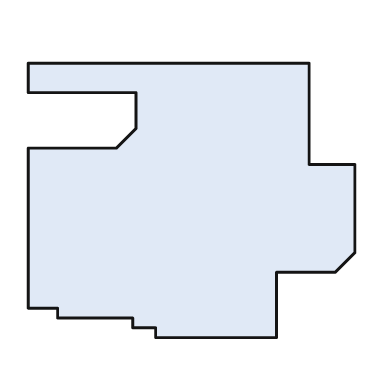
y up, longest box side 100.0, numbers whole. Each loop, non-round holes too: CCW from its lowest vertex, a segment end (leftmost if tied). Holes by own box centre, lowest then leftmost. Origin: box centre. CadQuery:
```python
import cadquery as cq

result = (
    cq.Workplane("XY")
    .moveTo(-11.0, -42.0)
    .lineTo(26.0, -42.0)
    .lineTo(26.0, -22.0)
    .lineTo(44.0, -22.0)
    .lineTo(50.0, -16.0)
    .lineTo(50.0, 11.0)
    .lineTo(36.0, 11.0)
    .lineTo(36.0, 42.0)
    .lineTo(-50.0, 42.0)
    .lineTo(-50.0, 33.0)
    .lineTo(-17.0, 33.0)
    .lineTo(-17.0, 22.0)
    .lineTo(-23.0, 16.0)
    .lineTo(-50.0, 16.0)
    .lineTo(-50.0, -33.0)
    .lineTo(-41.0, -33.0)
    .lineTo(-41.0, -36.0)
    .lineTo(-18.0, -36.0)
    .lineTo(-18.0, -39.0)
    .lineTo(-11.0, -39.0)
    .close()
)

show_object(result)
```